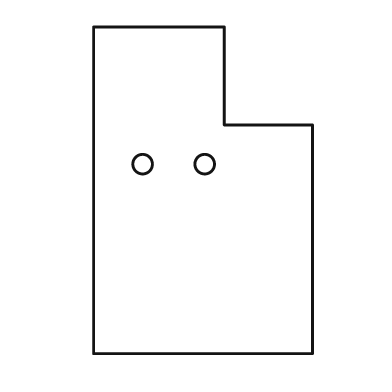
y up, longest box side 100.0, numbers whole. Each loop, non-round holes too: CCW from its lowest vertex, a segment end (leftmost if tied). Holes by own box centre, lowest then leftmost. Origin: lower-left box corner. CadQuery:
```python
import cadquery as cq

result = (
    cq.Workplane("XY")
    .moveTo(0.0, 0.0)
    .lineTo(67.0, 0.0)
    .lineTo(67.0, 70.0)
    .lineTo(40.0, 70.0)
    .lineTo(40.0, 100.0)
    .lineTo(0.0, 100.0)
    .close()
    .moveTo(15.0, 58.0)
    .circle(3.0)
    .moveTo(34.0, 58.0)
    .circle(3.0)
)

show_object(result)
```